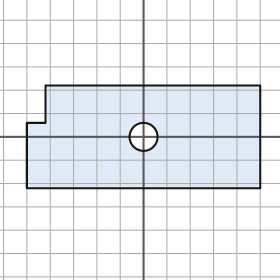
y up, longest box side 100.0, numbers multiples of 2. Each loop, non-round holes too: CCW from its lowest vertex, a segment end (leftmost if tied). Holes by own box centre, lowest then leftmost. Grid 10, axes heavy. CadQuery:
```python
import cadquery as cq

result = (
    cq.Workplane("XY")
    .moveTo(-50.0, -22.0)
    .lineTo(50.0, -22.0)
    .lineTo(50.0, 22.0)
    .lineTo(-42.0, 22.0)
    .lineTo(-42.0, 6.0)
    .lineTo(-50.0, 6.0)
    .close()
    .moveTo(0.0, 0.0)
    .circle(6.0)
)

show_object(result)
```